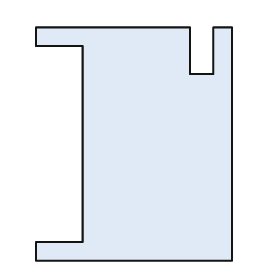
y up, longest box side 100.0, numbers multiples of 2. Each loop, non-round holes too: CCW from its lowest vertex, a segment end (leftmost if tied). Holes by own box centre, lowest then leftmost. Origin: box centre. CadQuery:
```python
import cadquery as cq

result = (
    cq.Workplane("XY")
    .moveTo(-42.0, -50.0)
    .lineTo(42.0, -50.0)
    .lineTo(42.0, 50.0)
    .lineTo(34.0, 50.0)
    .lineTo(34.0, 30.0)
    .lineTo(24.0, 30.0)
    .lineTo(24.0, 50.0)
    .lineTo(-42.0, 50.0)
    .lineTo(-42.0, 42.0)
    .lineTo(-22.0, 42.0)
    .lineTo(-22.0, -42.0)
    .lineTo(-42.0, -42.0)
    .close()
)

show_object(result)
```